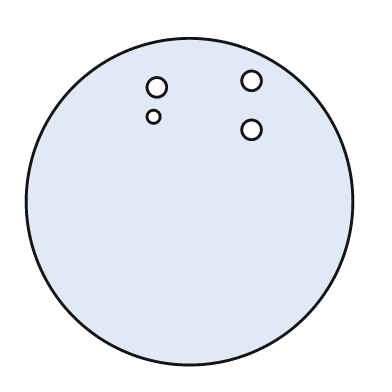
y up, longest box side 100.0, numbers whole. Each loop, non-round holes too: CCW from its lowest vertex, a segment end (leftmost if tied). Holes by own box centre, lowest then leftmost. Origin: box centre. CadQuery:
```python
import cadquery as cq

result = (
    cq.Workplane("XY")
    .moveTo(0.0, 0.0)
    .circle(50.0)
    .moveTo(19.0, 22.0)
    .circle(3.0)
    .moveTo(-11.0, 26.0)
    .circle(2.0)
    .moveTo(-10.0, 35.0)
    .circle(3.0)
    .moveTo(19.0, 37.0)
    .circle(3.0)
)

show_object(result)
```